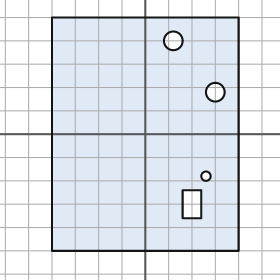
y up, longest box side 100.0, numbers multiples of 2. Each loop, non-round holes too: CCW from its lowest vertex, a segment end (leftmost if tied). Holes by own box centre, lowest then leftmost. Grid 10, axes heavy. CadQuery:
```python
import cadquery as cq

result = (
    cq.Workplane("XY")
    .moveTo(-40.0, -50.0)
    .lineTo(40.0, -50.0)
    .lineTo(40.0, 50.0)
    .lineTo(-40.0, 50.0)
    .close()
    .moveTo(16.0, -36.0)
    .lineTo(24.0, -36.0)
    .lineTo(24.0, -24.0)
    .lineTo(16.0, -24.0)
    .close()
    .moveTo(26.0, -18.0)
    .circle(2.0)
    .moveTo(30.0, 18.0)
    .circle(4.0)
    .moveTo(12.0, 40.0)
    .circle(4.0)
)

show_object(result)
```